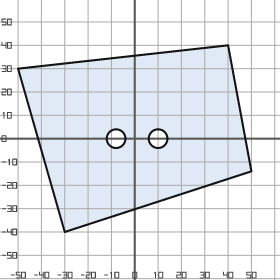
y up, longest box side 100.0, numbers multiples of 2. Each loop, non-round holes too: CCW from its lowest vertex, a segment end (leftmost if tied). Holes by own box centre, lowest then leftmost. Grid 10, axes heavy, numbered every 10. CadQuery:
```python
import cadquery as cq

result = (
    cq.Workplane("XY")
    .moveTo(-30.0, -40.0)
    .lineTo(50.0, -14.0)
    .lineTo(40.0, 40.0)
    .lineTo(-50.0, 30.0)
    .close()
    .moveTo(-8.0, 0.0)
    .circle(4.0)
    .moveTo(10.0, 0.0)
    .circle(4.0)
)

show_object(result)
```